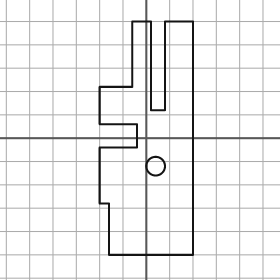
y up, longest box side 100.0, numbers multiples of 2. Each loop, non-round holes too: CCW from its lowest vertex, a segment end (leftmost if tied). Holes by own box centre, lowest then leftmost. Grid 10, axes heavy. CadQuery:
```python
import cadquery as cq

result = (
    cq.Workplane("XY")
    .moveTo(-16.0, -50.0)
    .lineTo(20.0, -50.0)
    .lineTo(20.0, 50.0)
    .lineTo(8.0, 50.0)
    .lineTo(8.0, 12.0)
    .lineTo(2.0, 12.0)
    .lineTo(2.0, 50.0)
    .lineTo(-6.0, 50.0)
    .lineTo(-6.0, 22.0)
    .lineTo(-20.0, 22.0)
    .lineTo(-20.0, 6.0)
    .lineTo(-4.0, 6.0)
    .lineTo(-4.0, -4.0)
    .lineTo(-20.0, -4.0)
    .lineTo(-20.0, -28.0)
    .lineTo(-16.0, -28.0)
    .close()
    .moveTo(4.0, -12.0)
    .circle(4.0)
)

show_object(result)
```